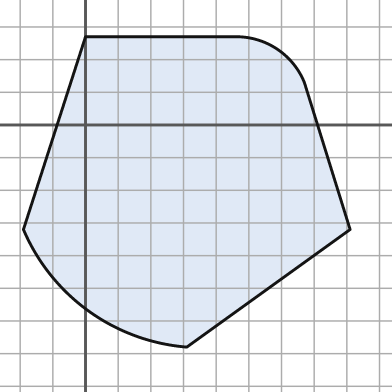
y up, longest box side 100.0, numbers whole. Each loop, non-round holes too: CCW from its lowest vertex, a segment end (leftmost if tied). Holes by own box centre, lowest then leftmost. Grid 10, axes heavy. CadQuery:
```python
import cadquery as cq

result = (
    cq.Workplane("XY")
    .moveTo(31.0, -68.0)
    .lineTo(81.0, -32.0)
    .lineTo(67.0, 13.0)
    .threePointArc((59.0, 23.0), (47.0, 27.0))
    .lineTo(0.0, 27.0)
    .lineTo(-19.0, -32.0)
    .threePointArc((1.0, -57.0), (31.0, -68.0))
    .close()
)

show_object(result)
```